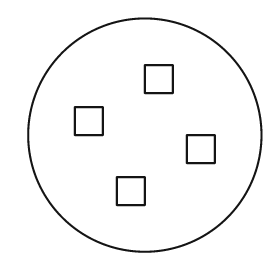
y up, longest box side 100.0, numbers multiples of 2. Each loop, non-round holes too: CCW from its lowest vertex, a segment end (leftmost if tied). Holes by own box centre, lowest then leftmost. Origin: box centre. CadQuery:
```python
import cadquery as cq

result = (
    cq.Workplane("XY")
    .moveTo(0.0, 0.0)
    .circle(50.0)
    .moveTo(-12.0, -30.0)
    .lineTo(0.0, -30.0)
    .lineTo(0.0, -18.0)
    .lineTo(-12.0, -18.0)
    .close()
    .moveTo(18.0, -12.0)
    .lineTo(30.0, -12.0)
    .lineTo(30.0, 0.0)
    .lineTo(18.0, 0.0)
    .close()
    .moveTo(-30.0, 0.0)
    .lineTo(-18.0, 0.0)
    .lineTo(-18.0, 12.0)
    .lineTo(-30.0, 12.0)
    .close()
    .moveTo(0.0, 18.0)
    .lineTo(12.0, 18.0)
    .lineTo(12.0, 30.0)
    .lineTo(0.0, 30.0)
    .close()
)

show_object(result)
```